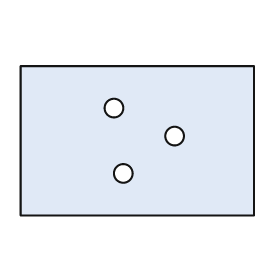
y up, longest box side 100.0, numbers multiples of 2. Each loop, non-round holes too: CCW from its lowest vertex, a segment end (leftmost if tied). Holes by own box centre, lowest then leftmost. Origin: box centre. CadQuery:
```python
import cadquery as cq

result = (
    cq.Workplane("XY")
    .moveTo(-50.0, -32.0)
    .lineTo(50.0, -32.0)
    .lineTo(50.0, 32.0)
    .lineTo(-50.0, 32.0)
    .close()
    .moveTo(-6.0, -14.0)
    .circle(4.0)
    .moveTo(16.0, 2.0)
    .circle(4.0)
    .moveTo(-10.0, 14.0)
    .circle(4.0)
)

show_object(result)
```